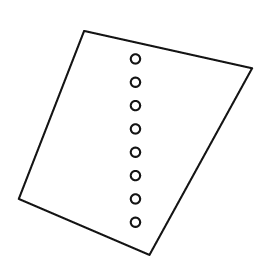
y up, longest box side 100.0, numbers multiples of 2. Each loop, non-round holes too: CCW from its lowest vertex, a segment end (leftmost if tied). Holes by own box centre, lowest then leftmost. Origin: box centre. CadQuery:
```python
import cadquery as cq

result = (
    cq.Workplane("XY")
    .moveTo(6.0, -48.0)
    .lineTo(50.0, 32.0)
    .lineTo(-22.0, 48.0)
    .lineTo(-50.0, -24.0)
    .close()
    .moveTo(0.0, -34.0)
    .circle(2.0)
    .moveTo(0.0, -24.0)
    .circle(2.0)
    .moveTo(0.0, -14.0)
    .circle(2.0)
    .moveTo(0.0, -4.0)
    .circle(2.0)
    .moveTo(0.0, 6.0)
    .circle(2.0)
    .moveTo(0.0, 16.0)
    .circle(2.0)
    .moveTo(0.0, 26.0)
    .circle(2.0)
    .moveTo(0.0, 36.0)
    .circle(2.0)
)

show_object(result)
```